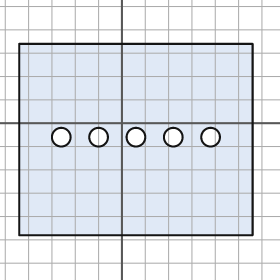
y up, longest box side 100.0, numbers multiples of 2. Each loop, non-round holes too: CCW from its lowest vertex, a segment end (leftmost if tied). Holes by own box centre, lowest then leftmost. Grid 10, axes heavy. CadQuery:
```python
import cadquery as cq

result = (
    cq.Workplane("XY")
    .moveTo(-44.0, -48.0)
    .lineTo(56.0, -48.0)
    .lineTo(56.0, 34.0)
    .lineTo(-44.0, 34.0)
    .close()
    .moveTo(-26.0, -6.0)
    .circle(4.0)
    .moveTo(-10.0, -6.0)
    .circle(4.0)
    .moveTo(6.0, -6.0)
    .circle(4.0)
    .moveTo(22.0, -6.0)
    .circle(4.0)
    .moveTo(38.0, -6.0)
    .circle(4.0)
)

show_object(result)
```